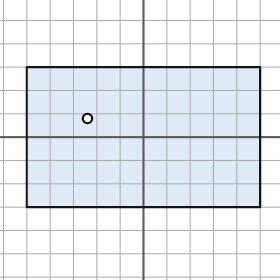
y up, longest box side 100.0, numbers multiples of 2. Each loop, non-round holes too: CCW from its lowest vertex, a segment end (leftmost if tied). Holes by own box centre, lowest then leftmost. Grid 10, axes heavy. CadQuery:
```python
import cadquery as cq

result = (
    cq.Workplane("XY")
    .moveTo(-50.0, -30.0)
    .lineTo(50.0, -30.0)
    .lineTo(50.0, 30.0)
    .lineTo(-50.0, 30.0)
    .close()
    .moveTo(-24.0, 8.0)
    .circle(2.0)
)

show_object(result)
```